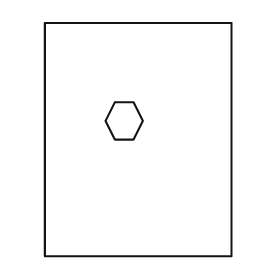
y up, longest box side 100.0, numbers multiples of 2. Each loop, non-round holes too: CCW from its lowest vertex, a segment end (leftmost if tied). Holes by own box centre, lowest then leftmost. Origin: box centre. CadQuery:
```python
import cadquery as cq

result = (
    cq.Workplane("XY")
    .moveTo(-40.0, -50.0)
    .lineTo(40.0, -50.0)
    .lineTo(40.0, 50.0)
    .lineTo(-40.0, 50.0)
    .close()
    .moveTo(-10.0, 0.0)
    .lineTo(-2.0, 0.0)
    .lineTo(2.0, 8.0)
    .lineTo(-2.0, 16.0)
    .lineTo(-10.0, 16.0)
    .lineTo(-14.0, 8.0)
    .close()
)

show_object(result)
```